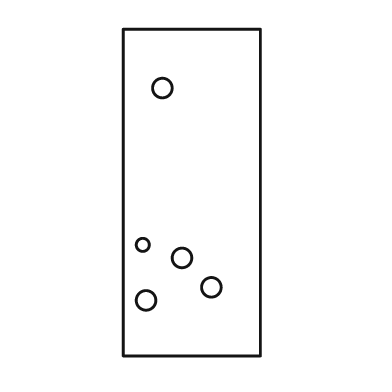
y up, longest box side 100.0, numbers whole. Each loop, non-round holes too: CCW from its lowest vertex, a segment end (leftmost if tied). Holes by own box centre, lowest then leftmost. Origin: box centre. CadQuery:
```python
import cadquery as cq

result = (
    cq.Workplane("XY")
    .moveTo(-21.0, -50.0)
    .lineTo(21.0, -50.0)
    .lineTo(21.0, 50.0)
    .lineTo(-21.0, 50.0)
    .close()
    .moveTo(-14.0, -33.0)
    .circle(3.0)
    .moveTo(6.0, -29.0)
    .circle(3.0)
    .moveTo(-3.0, -20.0)
    .circle(3.0)
    .moveTo(-15.0, -16.0)
    .circle(2.0)
    .moveTo(-9.0, 32.0)
    .circle(3.0)
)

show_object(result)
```